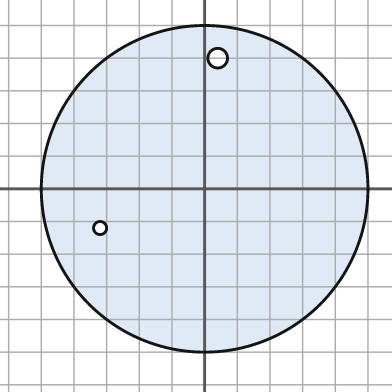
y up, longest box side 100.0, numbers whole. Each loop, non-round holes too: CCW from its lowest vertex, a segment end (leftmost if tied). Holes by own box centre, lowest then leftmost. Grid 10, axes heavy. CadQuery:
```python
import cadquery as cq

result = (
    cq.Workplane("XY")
    .moveTo(0.0, 0.0)
    .circle(50.0)
    .moveTo(-32.0, -12.0)
    .circle(2.0)
    .moveTo(4.0, 40.0)
    .circle(3.0)
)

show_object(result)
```